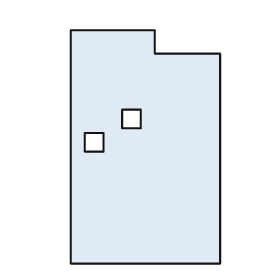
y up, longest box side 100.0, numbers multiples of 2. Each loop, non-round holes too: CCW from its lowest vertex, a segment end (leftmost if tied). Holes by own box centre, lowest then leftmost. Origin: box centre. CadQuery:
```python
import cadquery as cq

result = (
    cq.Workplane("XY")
    .moveTo(-32.0, -50.0)
    .lineTo(32.0, -50.0)
    .lineTo(32.0, 40.0)
    .lineTo(4.0, 40.0)
    .lineTo(4.0, 50.0)
    .lineTo(-32.0, 50.0)
    .close()
    .moveTo(-26.0, -2.0)
    .lineTo(-18.0, -2.0)
    .lineTo(-18.0, 6.0)
    .lineTo(-26.0, 6.0)
    .close()
    .moveTo(-10.0, 8.0)
    .lineTo(-2.0, 8.0)
    .lineTo(-2.0, 16.0)
    .lineTo(-10.0, 16.0)
    .close()
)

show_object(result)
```